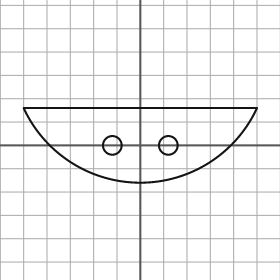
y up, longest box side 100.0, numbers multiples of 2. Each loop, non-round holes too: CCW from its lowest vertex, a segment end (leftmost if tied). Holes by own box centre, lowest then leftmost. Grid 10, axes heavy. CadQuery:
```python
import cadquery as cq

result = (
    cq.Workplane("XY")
    .moveTo(-50.0, 16.0)
    .threePointArc((0.0, -16.0), (50.0, 16.0))
    .close()
    .moveTo(-12.0, 0.0)
    .circle(4.0)
    .moveTo(12.0, 0.0)
    .circle(4.0)
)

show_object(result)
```